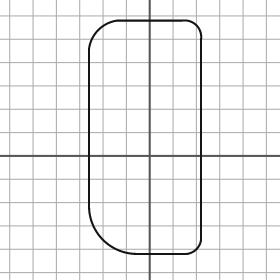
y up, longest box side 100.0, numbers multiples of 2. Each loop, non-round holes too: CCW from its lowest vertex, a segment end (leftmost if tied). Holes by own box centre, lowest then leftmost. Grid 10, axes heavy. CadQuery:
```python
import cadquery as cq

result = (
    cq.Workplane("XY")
    .moveTo(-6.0, -42.0)
    .lineTo(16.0, -42.0)
    .threePointArc((20.0, -40.0), (22.0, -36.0))
    .lineTo(22.0, 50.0)
    .threePointArc((20.0, 56.0), (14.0, 58.0))
    .lineTo(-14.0, 58.0)
    .threePointArc((-22.0, 54.0), (-26.0, 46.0))
    .lineTo(-26.0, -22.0)
    .threePointArc((-20.0, -36.0), (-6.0, -42.0))
    .close()
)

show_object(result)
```